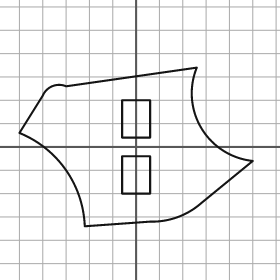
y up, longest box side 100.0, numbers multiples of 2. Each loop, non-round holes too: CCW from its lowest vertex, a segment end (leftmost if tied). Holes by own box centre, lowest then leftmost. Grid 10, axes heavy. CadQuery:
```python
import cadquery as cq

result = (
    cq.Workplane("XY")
    .moveTo(-22.0, -34.0)
    .lineTo(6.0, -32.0)
    .threePointArc((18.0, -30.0), (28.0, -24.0))
    .lineTo(50.0, -6.0)
    .threePointArc((28.0, 8.0), (26.0, 34.0))
    .lineTo(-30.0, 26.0)
    .threePointArc((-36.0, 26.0), (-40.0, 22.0))
    .lineTo(-50.0, 6.0)
    .threePointArc((-30.0, -10.0), (-22.0, -34.0))
    .close()
    .moveTo(-6.0, -20.0)
    .lineTo(6.0, -20.0)
    .lineTo(6.0, -4.0)
    .lineTo(-6.0, -4.0)
    .close()
    .moveTo(-6.0, 4.0)
    .lineTo(6.0, 4.0)
    .lineTo(6.0, 20.0)
    .lineTo(-6.0, 20.0)
    .close()
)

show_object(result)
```